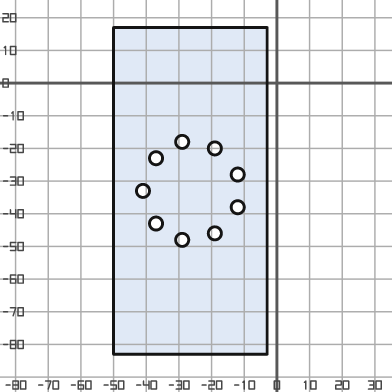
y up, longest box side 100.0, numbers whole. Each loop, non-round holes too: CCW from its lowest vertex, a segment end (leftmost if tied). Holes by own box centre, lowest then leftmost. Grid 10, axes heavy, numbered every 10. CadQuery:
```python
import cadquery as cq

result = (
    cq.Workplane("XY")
    .moveTo(-50.0, -83.0)
    .lineTo(-3.0, -83.0)
    .lineTo(-3.0, 17.0)
    .lineTo(-50.0, 17.0)
    .close()
    .moveTo(-29.0, -48.0)
    .circle(2.0)
    .moveTo(-19.0, -46.0)
    .circle(2.0)
    .moveTo(-37.0, -43.0)
    .circle(2.0)
    .moveTo(-12.0, -38.0)
    .circle(2.0)
    .moveTo(-41.0, -33.0)
    .circle(2.0)
    .moveTo(-12.0, -28.0)
    .circle(2.0)
    .moveTo(-37.0, -23.0)
    .circle(2.0)
    .moveTo(-19.0, -20.0)
    .circle(2.0)
    .moveTo(-29.0, -18.0)
    .circle(2.0)
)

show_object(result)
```